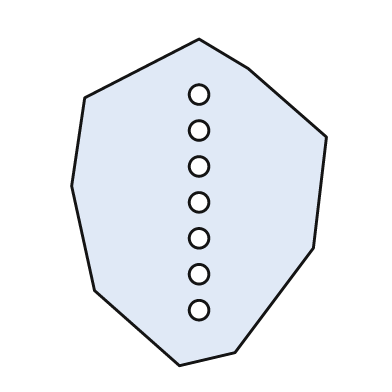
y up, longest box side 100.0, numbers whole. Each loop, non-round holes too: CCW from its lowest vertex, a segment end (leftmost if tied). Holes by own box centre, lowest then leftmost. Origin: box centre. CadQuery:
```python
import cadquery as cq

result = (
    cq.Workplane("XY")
    .moveTo(-6.0, -50.0)
    .lineTo(11.0, -46.0)
    .lineTo(35.0, -14.0)
    .lineTo(39.0, 20.0)
    .lineTo(15.0, 41.0)
    .lineTo(0.0, 50.0)
    .lineTo(-35.0, 32.0)
    .lineTo(-39.0, 5.0)
    .lineTo(-32.0, -27.0)
    .close()
    .moveTo(0.0, -33.0)
    .circle(3.0)
    .moveTo(0.0, -22.0)
    .circle(3.0)
    .moveTo(0.0, -11.0)
    .circle(3.0)
    .moveTo(0.0, 0.0)
    .circle(3.0)
    .moveTo(0.0, 11.0)
    .circle(3.0)
    .moveTo(0.0, 22.0)
    .circle(3.0)
    .moveTo(0.0, 33.0)
    .circle(3.0)
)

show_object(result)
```